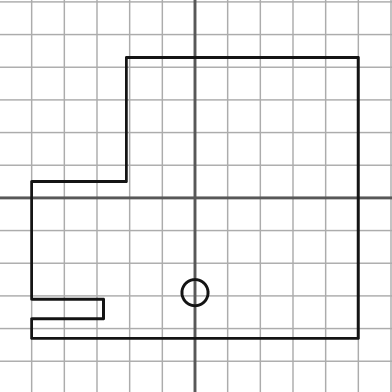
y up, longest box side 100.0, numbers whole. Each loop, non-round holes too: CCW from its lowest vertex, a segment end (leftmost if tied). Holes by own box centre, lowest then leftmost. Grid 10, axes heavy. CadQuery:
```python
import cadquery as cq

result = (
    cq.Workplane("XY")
    .moveTo(-50.0, -43.0)
    .lineTo(50.0, -43.0)
    .lineTo(50.0, 43.0)
    .lineTo(-21.0, 43.0)
    .lineTo(-21.0, 5.0)
    .lineTo(-50.0, 5.0)
    .lineTo(-50.0, -31.0)
    .lineTo(-28.0, -31.0)
    .lineTo(-28.0, -37.0)
    .lineTo(-50.0, -37.0)
    .close()
    .moveTo(0.0, -29.0)
    .circle(4.0)
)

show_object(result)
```